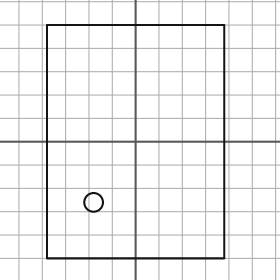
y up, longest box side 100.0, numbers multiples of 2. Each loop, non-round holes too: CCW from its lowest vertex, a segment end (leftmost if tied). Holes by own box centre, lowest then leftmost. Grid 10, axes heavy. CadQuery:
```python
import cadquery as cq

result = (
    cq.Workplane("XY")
    .moveTo(-38.0, -50.0)
    .lineTo(38.0, -50.0)
    .lineTo(38.0, 50.0)
    .lineTo(-38.0, 50.0)
    .close()
    .moveTo(-18.0, -26.0)
    .circle(4.0)
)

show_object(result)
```